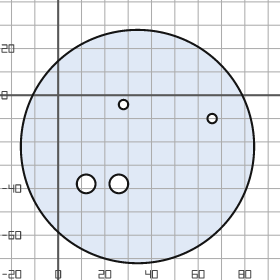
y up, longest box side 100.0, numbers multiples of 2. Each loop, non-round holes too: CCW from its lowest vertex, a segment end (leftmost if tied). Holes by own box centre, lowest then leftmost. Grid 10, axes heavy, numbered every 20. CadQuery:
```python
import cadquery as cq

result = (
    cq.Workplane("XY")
    .moveTo(34.0, -22.0)
    .circle(50.0)
    .moveTo(12.0, -38.0)
    .circle(4.0)
    .moveTo(26.0, -38.0)
    .circle(4.0)
    .moveTo(66.0, -10.0)
    .circle(2.0)
    .moveTo(28.0, -4.0)
    .circle(2.0)
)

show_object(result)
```